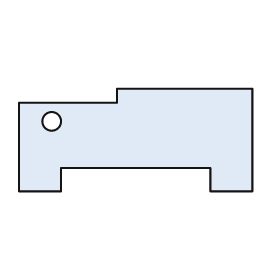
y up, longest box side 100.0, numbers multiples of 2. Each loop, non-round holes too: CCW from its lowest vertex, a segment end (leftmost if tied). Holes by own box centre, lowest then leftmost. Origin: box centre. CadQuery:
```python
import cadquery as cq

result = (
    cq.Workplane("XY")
    .moveTo(-50.0, -22.0)
    .lineTo(-32.0, -22.0)
    .lineTo(-32.0, -12.0)
    .lineTo(32.0, -12.0)
    .lineTo(32.0, -22.0)
    .lineTo(50.0, -22.0)
    .lineTo(50.0, 22.0)
    .lineTo(-8.0, 22.0)
    .lineTo(-8.0, 16.0)
    .lineTo(-50.0, 16.0)
    .close()
    .moveTo(-36.0, 8.0)
    .circle(4.0)
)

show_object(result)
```